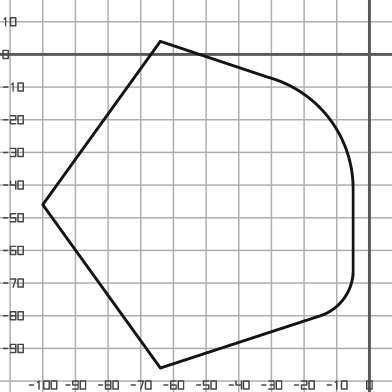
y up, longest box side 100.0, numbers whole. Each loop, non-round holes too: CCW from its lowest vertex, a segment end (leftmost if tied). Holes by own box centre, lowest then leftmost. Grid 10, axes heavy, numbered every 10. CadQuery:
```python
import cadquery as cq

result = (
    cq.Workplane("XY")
    .moveTo(-64.0, -96.0)
    .lineTo(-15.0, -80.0)
    .threePointArc((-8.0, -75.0), (-5.0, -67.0))
    .lineTo(-5.0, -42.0)
    .threePointArc((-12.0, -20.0), (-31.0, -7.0))
    .lineTo(-64.0, 4.0)
    .lineTo(-100.0, -46.0)
    .close()
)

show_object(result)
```